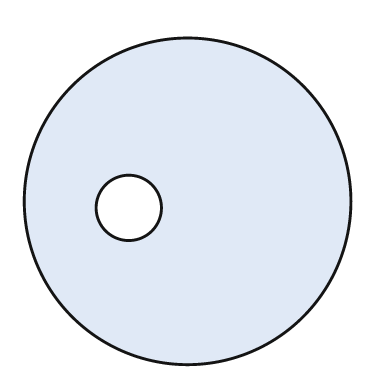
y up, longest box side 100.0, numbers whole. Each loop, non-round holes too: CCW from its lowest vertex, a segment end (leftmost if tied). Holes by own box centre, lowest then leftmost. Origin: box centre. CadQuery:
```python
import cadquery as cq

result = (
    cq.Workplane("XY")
    .moveTo(0.0, 0.0)
    .circle(50.0)
    .moveTo(-18.0, -2.0)
    .circle(10.0)
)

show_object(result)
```